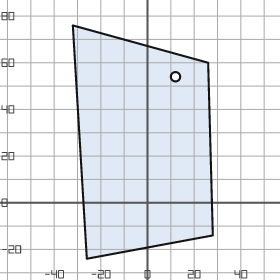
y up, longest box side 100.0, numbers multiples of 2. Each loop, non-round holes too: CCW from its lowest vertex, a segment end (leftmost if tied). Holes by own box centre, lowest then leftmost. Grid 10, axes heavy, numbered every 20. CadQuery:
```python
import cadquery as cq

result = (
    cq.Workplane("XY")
    .moveTo(-26.0, -24.0)
    .lineTo(28.0, -14.0)
    .lineTo(26.0, 60.0)
    .lineTo(-32.0, 76.0)
    .close()
    .moveTo(12.0, 54.0)
    .circle(2.0)
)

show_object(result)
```